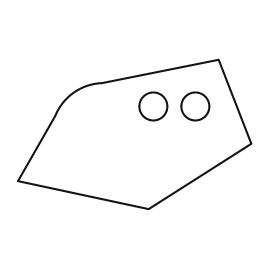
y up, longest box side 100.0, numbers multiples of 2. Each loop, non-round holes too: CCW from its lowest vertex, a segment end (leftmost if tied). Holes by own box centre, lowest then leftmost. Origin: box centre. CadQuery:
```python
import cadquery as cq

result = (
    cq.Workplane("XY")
    .moveTo(6.0, -32.0)
    .lineTo(50.0, -4.0)
    .lineTo(36.0, 32.0)
    .lineTo(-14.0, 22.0)
    .threePointArc((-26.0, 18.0), (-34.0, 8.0))
    .lineTo(-50.0, -20.0)
    .close()
    .moveTo(8.0, 12.0)
    .circle(6.0)
    .moveTo(26.0, 12.0)
    .circle(6.0)
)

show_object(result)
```